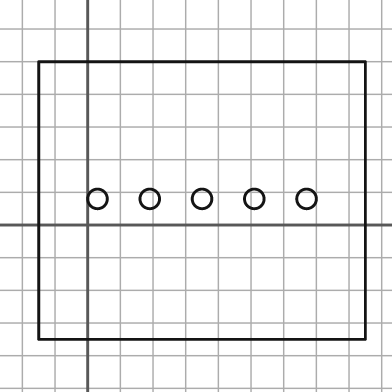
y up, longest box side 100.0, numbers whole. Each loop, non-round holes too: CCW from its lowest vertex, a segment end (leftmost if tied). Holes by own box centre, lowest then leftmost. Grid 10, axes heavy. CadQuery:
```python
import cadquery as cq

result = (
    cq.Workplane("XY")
    .moveTo(-15.0, -35.0)
    .lineTo(85.0, -35.0)
    .lineTo(85.0, 50.0)
    .lineTo(-15.0, 50.0)
    .close()
    .moveTo(3.0, 8.0)
    .circle(3.0)
    .moveTo(19.0, 8.0)
    .circle(3.0)
    .moveTo(35.0, 8.0)
    .circle(3.0)
    .moveTo(51.0, 8.0)
    .circle(3.0)
    .moveTo(67.0, 8.0)
    .circle(3.0)
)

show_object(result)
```